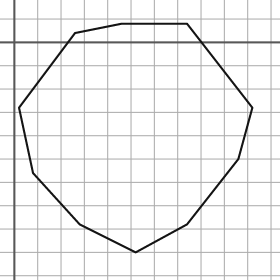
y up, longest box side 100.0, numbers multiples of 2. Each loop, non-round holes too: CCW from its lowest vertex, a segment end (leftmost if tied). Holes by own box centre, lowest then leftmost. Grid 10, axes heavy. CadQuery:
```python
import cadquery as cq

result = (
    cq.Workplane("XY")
    .moveTo(52.0, -90.0)
    .lineTo(74.0, -78.0)
    .lineTo(96.0, -50.0)
    .lineTo(102.0, -28.0)
    .lineTo(74.0, 8.0)
    .lineTo(46.0, 8.0)
    .lineTo(26.0, 4.0)
    .lineTo(2.0, -28.0)
    .lineTo(8.0, -56.0)
    .lineTo(28.0, -78.0)
    .close()
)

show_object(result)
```